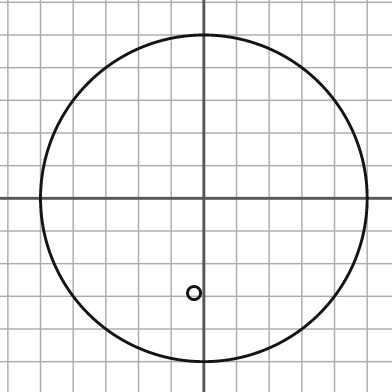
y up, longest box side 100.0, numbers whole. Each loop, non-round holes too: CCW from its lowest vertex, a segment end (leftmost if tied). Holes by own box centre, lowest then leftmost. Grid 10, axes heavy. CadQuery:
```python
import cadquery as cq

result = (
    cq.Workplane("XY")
    .moveTo(0.0, 0.0)
    .circle(50.0)
    .moveTo(-3.0, -29.0)
    .circle(2.0)
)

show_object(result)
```